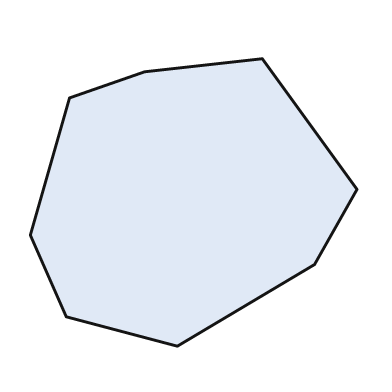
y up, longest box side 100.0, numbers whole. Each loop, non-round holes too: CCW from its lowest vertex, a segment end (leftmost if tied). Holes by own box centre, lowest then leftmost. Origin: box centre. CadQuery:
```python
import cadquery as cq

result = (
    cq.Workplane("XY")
    .moveTo(-5.0, -44.0)
    .lineTo(37.0, -19.0)
    .lineTo(50.0, 4.0)
    .lineTo(21.0, 44.0)
    .lineTo(-15.0, 40.0)
    .lineTo(-38.0, 32.0)
    .lineTo(-50.0, -10.0)
    .lineTo(-39.0, -35.0)
    .close()
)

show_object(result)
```